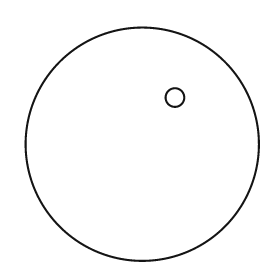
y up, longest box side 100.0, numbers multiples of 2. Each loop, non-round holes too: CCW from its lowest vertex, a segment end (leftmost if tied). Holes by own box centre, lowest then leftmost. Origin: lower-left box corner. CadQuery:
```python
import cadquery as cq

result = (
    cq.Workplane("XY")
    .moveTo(50.0, 50.0)
    .circle(50.0)
    .moveTo(64.0, 70.0)
    .circle(4.0)
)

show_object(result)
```